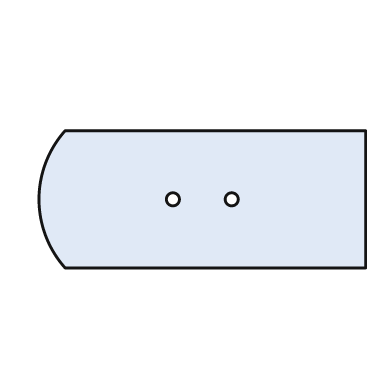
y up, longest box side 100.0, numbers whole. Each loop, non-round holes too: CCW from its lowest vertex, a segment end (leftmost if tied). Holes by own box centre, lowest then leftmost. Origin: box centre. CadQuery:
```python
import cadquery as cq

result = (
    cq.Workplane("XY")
    .moveTo(-42.0, -21.0)
    .lineTo(50.0, -21.0)
    .lineTo(50.0, 21.0)
    .lineTo(-42.0, 21.0)
    .threePointArc((-50.0, 0.0), (-42.0, -21.0))
    .close()
    .moveTo(-9.0, 0.0)
    .circle(2.0)
    .moveTo(9.0, 0.0)
    .circle(2.0)
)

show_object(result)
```